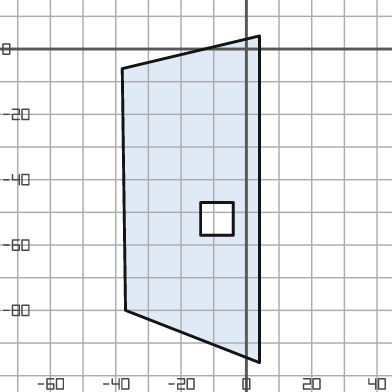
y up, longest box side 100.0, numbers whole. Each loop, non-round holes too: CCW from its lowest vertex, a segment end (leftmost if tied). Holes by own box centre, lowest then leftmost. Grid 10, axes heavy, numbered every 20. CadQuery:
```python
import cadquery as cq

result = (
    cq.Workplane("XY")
    .moveTo(4.0, -96.0)
    .lineTo(4.0, 4.0)
    .lineTo(-38.0, -6.0)
    .lineTo(-37.0, -80.0)
    .close()
    .moveTo(-14.0, -57.0)
    .lineTo(-4.0, -57.0)
    .lineTo(-4.0, -47.0)
    .lineTo(-14.0, -47.0)
    .close()
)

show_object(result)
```